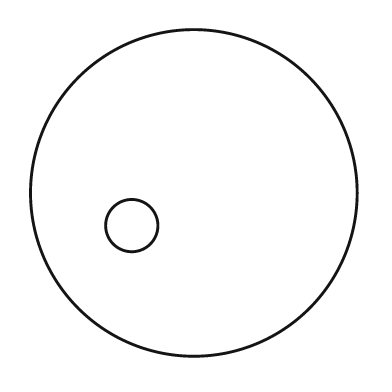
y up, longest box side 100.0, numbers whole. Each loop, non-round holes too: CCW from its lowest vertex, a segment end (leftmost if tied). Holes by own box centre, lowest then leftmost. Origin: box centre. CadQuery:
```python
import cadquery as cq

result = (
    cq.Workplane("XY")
    .moveTo(0.0, 0.0)
    .circle(50.0)
    .moveTo(-19.0, -10.0)
    .circle(8.0)
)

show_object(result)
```